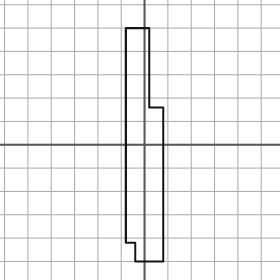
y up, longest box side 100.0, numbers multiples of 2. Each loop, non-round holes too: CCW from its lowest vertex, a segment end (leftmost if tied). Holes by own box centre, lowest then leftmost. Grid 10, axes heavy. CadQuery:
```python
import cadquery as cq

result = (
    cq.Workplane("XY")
    .moveTo(-4.0, -50.0)
    .lineTo(8.0, -50.0)
    .lineTo(8.0, 16.0)
    .lineTo(2.0, 16.0)
    .lineTo(2.0, 50.0)
    .lineTo(-8.0, 50.0)
    .lineTo(-8.0, -42.0)
    .lineTo(-4.0, -42.0)
    .close()
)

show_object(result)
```